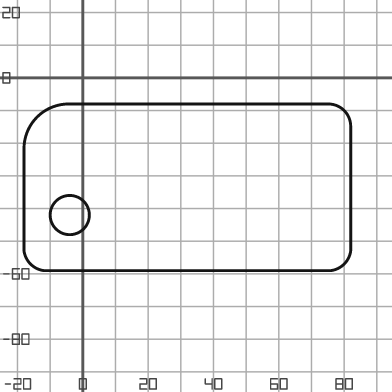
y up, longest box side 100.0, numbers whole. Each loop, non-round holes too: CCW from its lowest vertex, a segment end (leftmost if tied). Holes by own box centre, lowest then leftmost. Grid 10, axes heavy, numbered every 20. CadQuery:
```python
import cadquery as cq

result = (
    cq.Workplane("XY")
    .moveTo(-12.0, -59.0)
    .lineTo(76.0, -59.0)
    .threePointArc((80.0, -57.0), (82.0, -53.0))
    .lineTo(82.0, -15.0)
    .threePointArc((80.0, -10.0), (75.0, -8.0))
    .lineTo(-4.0, -8.0)
    .threePointArc((-14.0, -12.0), (-18.0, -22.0))
    .lineTo(-18.0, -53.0)
    .threePointArc((-16.0, -57.0), (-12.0, -59.0))
    .close()
    .moveTo(-4.0, -42.0)
    .circle(6.0)
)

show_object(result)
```